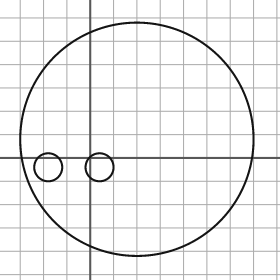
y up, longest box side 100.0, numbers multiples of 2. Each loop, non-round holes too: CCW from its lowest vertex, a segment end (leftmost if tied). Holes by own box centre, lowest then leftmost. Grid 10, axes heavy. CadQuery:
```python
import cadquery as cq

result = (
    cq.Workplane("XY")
    .moveTo(20.0, 8.0)
    .circle(50.0)
    .moveTo(-18.0, -4.0)
    .circle(6.0)
    .moveTo(4.0, -4.0)
    .circle(6.0)
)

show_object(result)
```